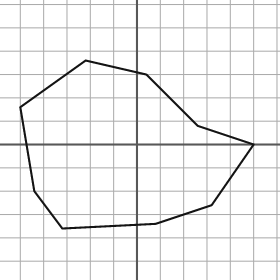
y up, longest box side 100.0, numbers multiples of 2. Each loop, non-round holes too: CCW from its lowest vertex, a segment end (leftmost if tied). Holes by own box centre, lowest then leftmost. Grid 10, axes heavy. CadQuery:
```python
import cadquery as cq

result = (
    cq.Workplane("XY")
    .moveTo(-32.0, -36.0)
    .lineTo(8.0, -34.0)
    .lineTo(32.0, -26.0)
    .lineTo(50.0, 0.0)
    .lineTo(26.0, 8.0)
    .lineTo(4.0, 30.0)
    .lineTo(-22.0, 36.0)
    .lineTo(-50.0, 16.0)
    .lineTo(-44.0, -20.0)
    .close()
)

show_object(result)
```